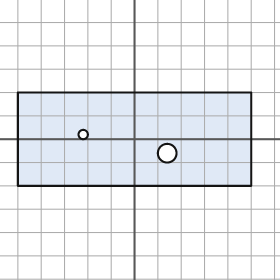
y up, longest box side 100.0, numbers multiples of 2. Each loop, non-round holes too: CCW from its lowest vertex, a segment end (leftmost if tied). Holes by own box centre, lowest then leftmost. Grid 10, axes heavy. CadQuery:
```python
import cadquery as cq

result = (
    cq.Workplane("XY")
    .moveTo(-50.0, -20.0)
    .lineTo(50.0, -20.0)
    .lineTo(50.0, 20.0)
    .lineTo(-50.0, 20.0)
    .close()
    .moveTo(14.0, -6.0)
    .circle(4.0)
    .moveTo(-22.0, 2.0)
    .circle(2.0)
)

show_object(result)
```